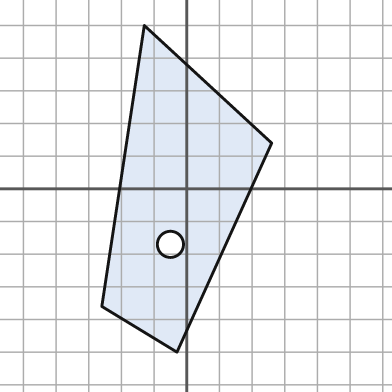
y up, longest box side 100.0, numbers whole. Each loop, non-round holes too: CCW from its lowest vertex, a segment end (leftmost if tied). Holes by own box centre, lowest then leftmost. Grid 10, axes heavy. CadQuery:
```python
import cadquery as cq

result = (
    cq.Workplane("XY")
    .moveTo(-3.0, -50.0)
    .lineTo(26.0, 14.0)
    .lineTo(-13.0, 50.0)
    .lineTo(-26.0, -36.0)
    .close()
    .moveTo(-5.0, -17.0)
    .circle(4.0)
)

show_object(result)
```